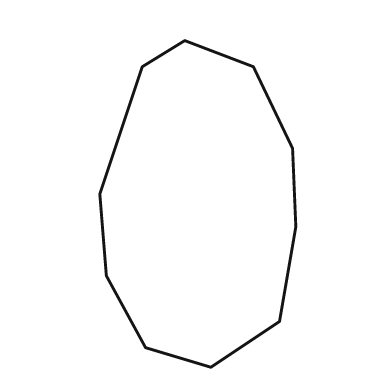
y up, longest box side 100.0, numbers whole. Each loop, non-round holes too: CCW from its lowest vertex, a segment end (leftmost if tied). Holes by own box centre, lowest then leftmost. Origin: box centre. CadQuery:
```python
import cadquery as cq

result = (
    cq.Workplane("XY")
    .moveTo(4.0, -50.0)
    .lineTo(25.0, -36.0)
    .lineTo(30.0, -7.0)
    .lineTo(29.0, 17.0)
    .lineTo(17.0, 42.0)
    .lineTo(-4.0, 50.0)
    .lineTo(-17.0, 42.0)
    .lineTo(-30.0, 3.0)
    .lineTo(-28.0, -22.0)
    .lineTo(-16.0, -44.0)
    .close()
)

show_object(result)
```